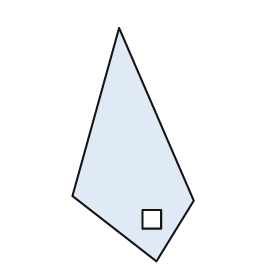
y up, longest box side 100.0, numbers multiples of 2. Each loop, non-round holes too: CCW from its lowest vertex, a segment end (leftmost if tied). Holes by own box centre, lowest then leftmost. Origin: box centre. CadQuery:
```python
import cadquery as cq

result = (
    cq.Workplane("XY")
    .moveTo(10.0, -50.0)
    .lineTo(26.0, -24.0)
    .lineTo(-6.0, 50.0)
    .lineTo(-26.0, -22.0)
    .close()
    .moveTo(4.0, -36.0)
    .lineTo(12.0, -36.0)
    .lineTo(12.0, -28.0)
    .lineTo(4.0, -28.0)
    .close()
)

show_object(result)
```